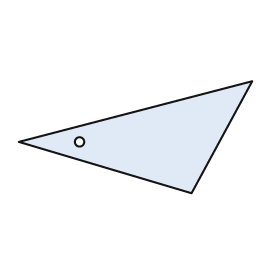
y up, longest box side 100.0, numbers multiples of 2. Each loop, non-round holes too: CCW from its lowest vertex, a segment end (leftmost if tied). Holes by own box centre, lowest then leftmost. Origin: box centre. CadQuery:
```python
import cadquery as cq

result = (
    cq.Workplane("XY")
    .moveTo(24.0, -24.0)
    .lineTo(50.0, 24.0)
    .lineTo(-50.0, -2.0)
    .close()
    .moveTo(-24.0, -2.0)
    .circle(2.0)
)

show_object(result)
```